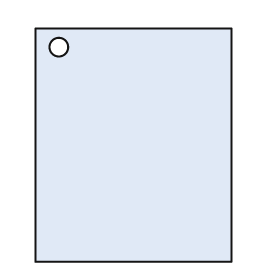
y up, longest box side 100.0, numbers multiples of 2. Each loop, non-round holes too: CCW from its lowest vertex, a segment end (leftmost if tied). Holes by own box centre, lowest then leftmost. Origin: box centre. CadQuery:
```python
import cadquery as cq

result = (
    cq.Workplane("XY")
    .moveTo(-42.0, -50.0)
    .lineTo(42.0, -50.0)
    .lineTo(42.0, 50.0)
    .lineTo(-42.0, 50.0)
    .close()
    .moveTo(-32.0, 42.0)
    .circle(4.0)
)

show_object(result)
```